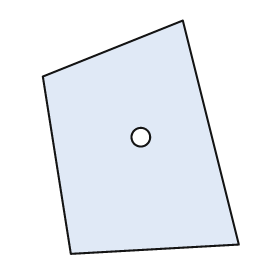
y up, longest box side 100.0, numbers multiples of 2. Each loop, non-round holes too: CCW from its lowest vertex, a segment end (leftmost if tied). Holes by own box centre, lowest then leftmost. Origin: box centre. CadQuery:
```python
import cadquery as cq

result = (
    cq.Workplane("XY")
    .moveTo(-30.0, -50.0)
    .lineTo(42.0, -46.0)
    .lineTo(18.0, 50.0)
    .lineTo(-42.0, 26.0)
    .close()
    .moveTo(0.0, 0.0)
    .circle(4.0)
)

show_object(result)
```